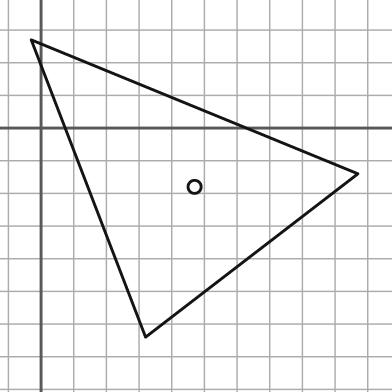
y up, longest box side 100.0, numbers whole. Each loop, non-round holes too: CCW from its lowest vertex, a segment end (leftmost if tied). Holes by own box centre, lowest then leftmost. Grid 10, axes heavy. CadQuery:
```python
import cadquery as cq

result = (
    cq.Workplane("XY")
    .moveTo(32.0, -64.0)
    .lineTo(97.0, -14.0)
    .lineTo(-3.0, 27.0)
    .close()
    .moveTo(47.0, -18.0)
    .circle(2.0)
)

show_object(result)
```